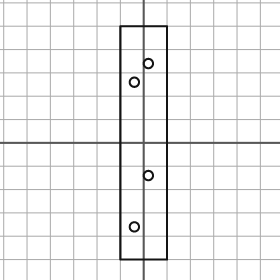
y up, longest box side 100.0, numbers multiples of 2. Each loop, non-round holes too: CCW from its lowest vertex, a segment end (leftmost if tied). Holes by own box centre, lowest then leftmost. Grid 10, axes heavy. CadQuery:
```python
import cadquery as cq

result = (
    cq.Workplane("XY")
    .moveTo(-10.0, -50.0)
    .lineTo(10.0, -50.0)
    .lineTo(10.0, 50.0)
    .lineTo(-10.0, 50.0)
    .close()
    .moveTo(-4.0, -36.0)
    .circle(2.0)
    .moveTo(2.0, -14.0)
    .circle(2.0)
    .moveTo(-4.0, 26.0)
    .circle(2.0)
    .moveTo(2.0, 34.0)
    .circle(2.0)
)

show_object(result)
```